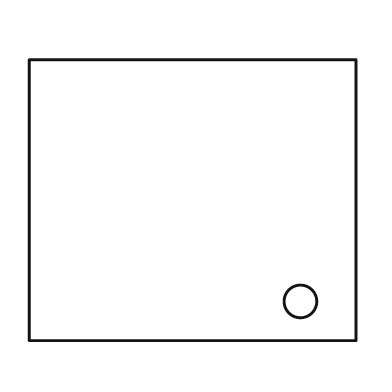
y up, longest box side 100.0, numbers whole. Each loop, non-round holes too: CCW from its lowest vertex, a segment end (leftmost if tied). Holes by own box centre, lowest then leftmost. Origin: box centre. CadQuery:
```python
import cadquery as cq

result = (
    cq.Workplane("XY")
    .moveTo(-50.0, -43.0)
    .lineTo(50.0, -43.0)
    .lineTo(50.0, 43.0)
    .lineTo(-50.0, 43.0)
    .close()
    .moveTo(33.0, -31.0)
    .circle(5.0)
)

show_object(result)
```